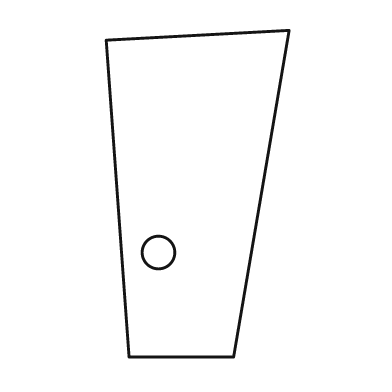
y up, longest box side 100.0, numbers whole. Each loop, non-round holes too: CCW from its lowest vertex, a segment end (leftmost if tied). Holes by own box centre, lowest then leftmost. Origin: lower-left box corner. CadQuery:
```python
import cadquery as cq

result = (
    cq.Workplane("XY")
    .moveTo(7.0, 0.0)
    .lineTo(39.0, 0.0)
    .lineTo(56.0, 100.0)
    .lineTo(0.0, 97.0)
    .close()
    .moveTo(16.0, 32.0)
    .circle(5.0)
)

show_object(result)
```